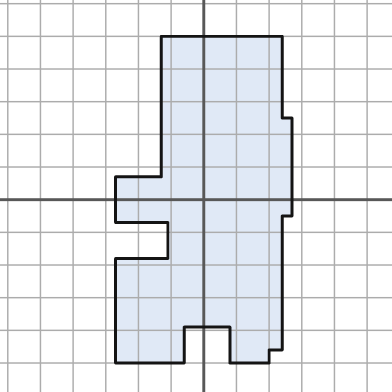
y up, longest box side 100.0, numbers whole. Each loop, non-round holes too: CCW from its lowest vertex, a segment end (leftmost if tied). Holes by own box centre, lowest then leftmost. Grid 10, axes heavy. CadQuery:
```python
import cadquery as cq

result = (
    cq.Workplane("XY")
    .moveTo(-27.0, -50.0)
    .lineTo(-6.0, -50.0)
    .lineTo(-6.0, -39.0)
    .lineTo(8.0, -39.0)
    .lineTo(8.0, -50.0)
    .lineTo(20.0, -50.0)
    .lineTo(20.0, -46.0)
    .lineTo(24.0, -46.0)
    .lineTo(24.0, -5.0)
    .lineTo(27.0, -5.0)
    .lineTo(27.0, 25.0)
    .lineTo(24.0, 25.0)
    .lineTo(24.0, 50.0)
    .lineTo(-13.0, 50.0)
    .lineTo(-13.0, 7.0)
    .lineTo(-27.0, 7.0)
    .lineTo(-27.0, -7.0)
    .lineTo(-11.0, -7.0)
    .lineTo(-11.0, -18.0)
    .lineTo(-27.0, -18.0)
    .close()
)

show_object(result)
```